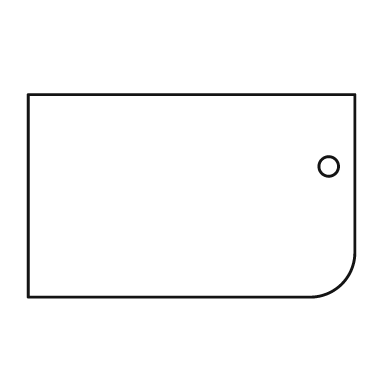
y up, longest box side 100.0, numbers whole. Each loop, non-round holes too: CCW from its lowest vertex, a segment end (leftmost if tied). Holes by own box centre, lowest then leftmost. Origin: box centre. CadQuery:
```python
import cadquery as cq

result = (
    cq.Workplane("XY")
    .moveTo(-50.0, -31.0)
    .lineTo(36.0, -31.0)
    .threePointArc((46.0, -27.0), (50.0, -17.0))
    .lineTo(50.0, 31.0)
    .lineTo(-50.0, 31.0)
    .close()
    .moveTo(42.0, 9.0)
    .circle(3.0)
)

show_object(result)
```